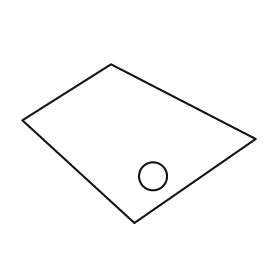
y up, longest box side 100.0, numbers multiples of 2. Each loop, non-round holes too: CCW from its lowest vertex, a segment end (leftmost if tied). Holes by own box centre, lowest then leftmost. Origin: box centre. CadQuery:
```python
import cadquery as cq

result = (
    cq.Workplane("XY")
    .moveTo(-2.0, -34.0)
    .lineTo(50.0, 2.0)
    .lineTo(-12.0, 34.0)
    .lineTo(-50.0, 10.0)
    .close()
    .moveTo(6.0, -14.0)
    .circle(6.0)
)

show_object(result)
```